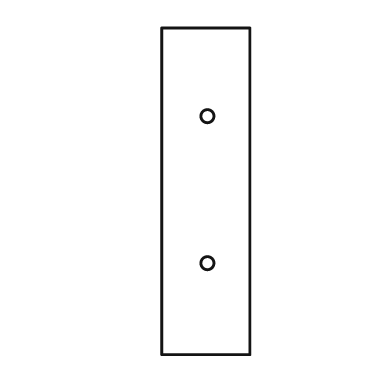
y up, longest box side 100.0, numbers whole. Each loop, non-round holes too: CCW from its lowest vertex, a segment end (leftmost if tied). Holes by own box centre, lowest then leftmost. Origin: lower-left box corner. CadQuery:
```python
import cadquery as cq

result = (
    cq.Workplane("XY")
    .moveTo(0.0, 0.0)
    .lineTo(27.0, 0.0)
    .lineTo(27.0, 100.0)
    .lineTo(0.0, 100.0)
    .close()
    .moveTo(14.0, 28.0)
    .circle(2.0)
    .moveTo(14.0, 73.0)
    .circle(2.0)
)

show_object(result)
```